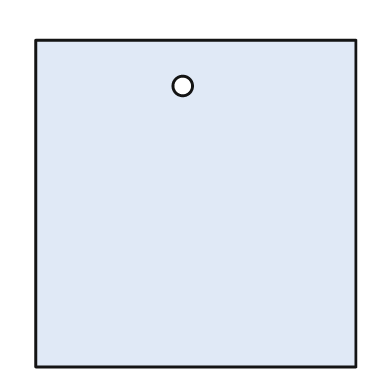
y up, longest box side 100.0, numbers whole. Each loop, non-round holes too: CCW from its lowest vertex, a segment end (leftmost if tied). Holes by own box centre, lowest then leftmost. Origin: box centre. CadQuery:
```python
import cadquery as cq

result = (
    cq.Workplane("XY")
    .moveTo(-49.0, -50.0)
    .lineTo(49.0, -50.0)
    .lineTo(49.0, 50.0)
    .lineTo(-49.0, 50.0)
    .close()
    .moveTo(-4.0, 36.0)
    .circle(3.0)
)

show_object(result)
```